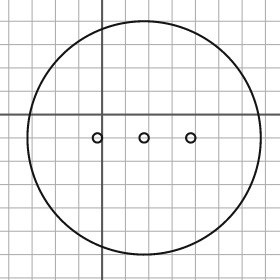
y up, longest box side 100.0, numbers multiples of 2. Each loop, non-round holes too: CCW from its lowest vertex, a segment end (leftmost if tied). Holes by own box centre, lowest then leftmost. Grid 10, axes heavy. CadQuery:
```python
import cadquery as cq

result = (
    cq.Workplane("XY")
    .moveTo(18.0, -10.0)
    .circle(50.0)
    .moveTo(-2.0, -10.0)
    .circle(2.0)
    .moveTo(18.0, -10.0)
    .circle(2.0)
    .moveTo(38.0, -10.0)
    .circle(2.0)
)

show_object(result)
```